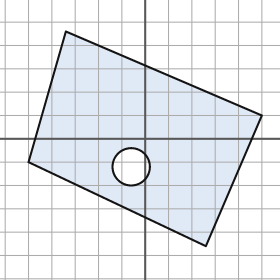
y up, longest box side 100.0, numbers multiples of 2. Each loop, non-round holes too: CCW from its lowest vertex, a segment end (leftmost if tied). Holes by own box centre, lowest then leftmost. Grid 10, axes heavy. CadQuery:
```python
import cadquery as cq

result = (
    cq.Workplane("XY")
    .moveTo(26.0, -46.0)
    .lineTo(50.0, 10.0)
    .lineTo(-34.0, 46.0)
    .lineTo(-50.0, -10.0)
    .close()
    .moveTo(-6.0, -12.0)
    .circle(8.0)
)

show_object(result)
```